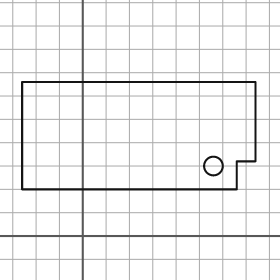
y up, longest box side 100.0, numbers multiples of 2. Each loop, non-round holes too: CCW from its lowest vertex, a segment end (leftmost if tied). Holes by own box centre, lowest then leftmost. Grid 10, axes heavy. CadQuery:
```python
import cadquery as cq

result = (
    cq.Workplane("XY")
    .moveTo(-26.0, 20.0)
    .lineTo(66.0, 20.0)
    .lineTo(66.0, 32.0)
    .lineTo(74.0, 32.0)
    .lineTo(74.0, 66.0)
    .lineTo(-26.0, 66.0)
    .close()
    .moveTo(56.0, 30.0)
    .circle(4.0)
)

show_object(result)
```